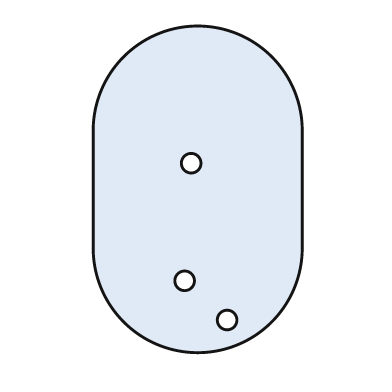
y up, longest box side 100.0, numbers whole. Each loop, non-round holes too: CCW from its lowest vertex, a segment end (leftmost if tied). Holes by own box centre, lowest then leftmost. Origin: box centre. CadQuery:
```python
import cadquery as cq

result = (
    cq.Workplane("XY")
    .moveTo(-32.0, -18.0)
    .threePointArc((0.0, -50.0), (32.0, -18.0))
    .lineTo(32.0, 18.0)
    .threePointArc((0.0, 50.0), (-32.0, 18.0))
    .close()
    .moveTo(9.0, -40.0)
    .circle(3.0)
    .moveTo(-4.0, -28.0)
    .circle(3.0)
    .moveTo(-2.0, 8.0)
    .circle(3.0)
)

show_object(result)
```